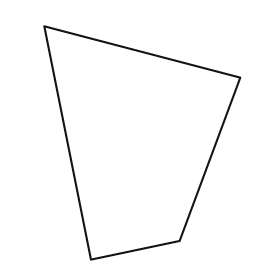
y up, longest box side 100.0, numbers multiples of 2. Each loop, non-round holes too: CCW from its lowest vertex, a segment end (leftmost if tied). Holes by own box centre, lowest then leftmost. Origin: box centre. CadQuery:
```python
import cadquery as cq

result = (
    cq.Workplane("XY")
    .moveTo(-22.0, -50.0)
    .lineTo(16.0, -42.0)
    .lineTo(42.0, 28.0)
    .lineTo(-42.0, 50.0)
    .close()
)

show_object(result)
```